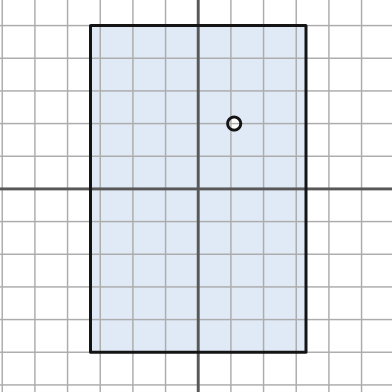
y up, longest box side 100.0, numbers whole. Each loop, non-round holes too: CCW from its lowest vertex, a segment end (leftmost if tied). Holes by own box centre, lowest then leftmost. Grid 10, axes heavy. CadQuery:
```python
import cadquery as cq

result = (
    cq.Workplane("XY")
    .moveTo(-33.0, -50.0)
    .lineTo(33.0, -50.0)
    .lineTo(33.0, 50.0)
    .lineTo(-33.0, 50.0)
    .close()
    .moveTo(11.0, 20.0)
    .circle(2.0)
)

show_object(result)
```